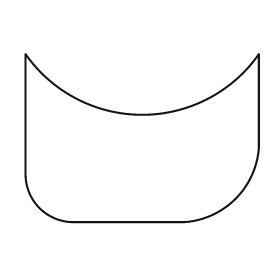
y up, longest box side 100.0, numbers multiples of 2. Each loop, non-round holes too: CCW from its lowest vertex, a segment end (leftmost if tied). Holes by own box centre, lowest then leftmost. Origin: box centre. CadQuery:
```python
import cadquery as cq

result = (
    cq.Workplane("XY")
    .moveTo(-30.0, -36.0)
    .lineTo(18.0, -36.0)
    .threePointArc((40.0, -26.0), (50.0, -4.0))
    .lineTo(50.0, 36.0)
    .threePointArc((0.0, 10.0), (-50.0, 36.0))
    .lineTo(-50.0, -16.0)
    .threePointArc((-44.0, -30.0), (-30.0, -36.0))
    .close()
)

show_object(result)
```